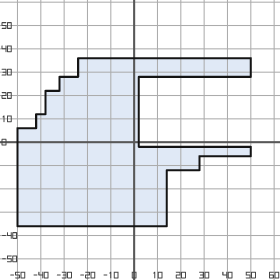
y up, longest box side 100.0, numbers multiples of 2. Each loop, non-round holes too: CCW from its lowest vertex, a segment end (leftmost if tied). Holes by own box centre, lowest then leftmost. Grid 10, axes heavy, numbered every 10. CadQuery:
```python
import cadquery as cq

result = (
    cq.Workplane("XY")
    .moveTo(-50.0, -36.0)
    .lineTo(14.0, -36.0)
    .lineTo(14.0, -12.0)
    .lineTo(28.0, -12.0)
    .lineTo(28.0, -6.0)
    .lineTo(50.0, -6.0)
    .lineTo(50.0, -2.0)
    .lineTo(2.0, -2.0)
    .lineTo(2.0, 28.0)
    .lineTo(50.0, 28.0)
    .lineTo(50.0, 36.0)
    .lineTo(-24.0, 36.0)
    .lineTo(-24.0, 28.0)
    .lineTo(-32.0, 28.0)
    .lineTo(-32.0, 22.0)
    .lineTo(-38.0, 22.0)
    .lineTo(-38.0, 12.0)
    .lineTo(-42.0, 12.0)
    .lineTo(-42.0, 6.0)
    .lineTo(-50.0, 6.0)
    .close()
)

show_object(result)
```